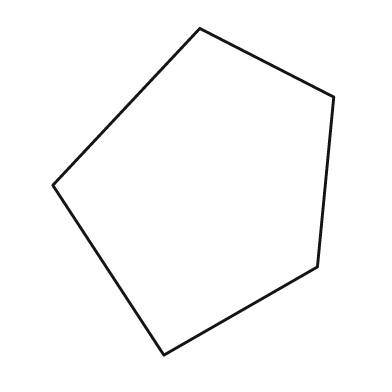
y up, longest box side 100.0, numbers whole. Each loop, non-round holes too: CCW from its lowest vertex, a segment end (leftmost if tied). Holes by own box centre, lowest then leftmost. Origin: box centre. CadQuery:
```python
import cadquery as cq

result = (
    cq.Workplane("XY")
    .moveTo(-9.0, -50.0)
    .lineTo(38.0, -23.0)
    .lineTo(43.0, 29.0)
    .lineTo(2.0, 50.0)
    .lineTo(-43.0, 2.0)
    .close()
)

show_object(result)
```